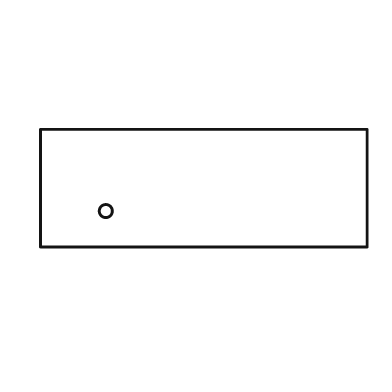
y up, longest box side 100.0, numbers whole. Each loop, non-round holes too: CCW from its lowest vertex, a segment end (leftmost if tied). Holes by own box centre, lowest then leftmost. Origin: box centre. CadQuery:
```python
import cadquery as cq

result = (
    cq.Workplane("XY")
    .moveTo(-50.0, -18.0)
    .lineTo(50.0, -18.0)
    .lineTo(50.0, 18.0)
    .lineTo(-50.0, 18.0)
    .close()
    .moveTo(-30.0, -7.0)
    .circle(2.0)
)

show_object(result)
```